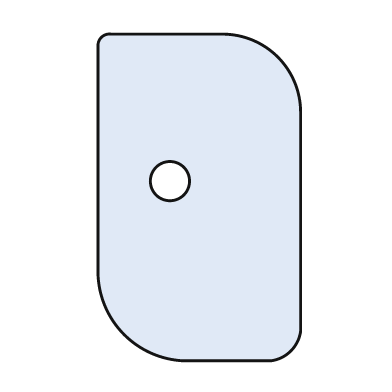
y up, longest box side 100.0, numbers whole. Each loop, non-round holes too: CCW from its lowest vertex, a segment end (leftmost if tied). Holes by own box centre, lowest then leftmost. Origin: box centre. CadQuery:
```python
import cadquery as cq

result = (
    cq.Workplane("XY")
    .moveTo(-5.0, -50.0)
    .lineTo(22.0, -50.0)
    .threePointArc((28.0, -47.0), (31.0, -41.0))
    .lineTo(31.0, 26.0)
    .threePointArc((24.0, 43.0), (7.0, 50.0))
    .lineTo(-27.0, 50.0)
    .threePointArc((-30.0, 49.0), (-31.0, 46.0))
    .lineTo(-31.0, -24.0)
    .threePointArc((-23.0, -42.0), (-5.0, -50.0))
    .close()
    .moveTo(-9.0, 5.0)
    .circle(6.0)
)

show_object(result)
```